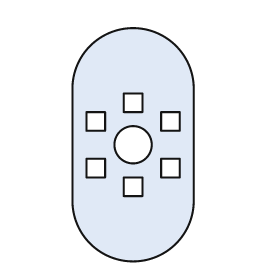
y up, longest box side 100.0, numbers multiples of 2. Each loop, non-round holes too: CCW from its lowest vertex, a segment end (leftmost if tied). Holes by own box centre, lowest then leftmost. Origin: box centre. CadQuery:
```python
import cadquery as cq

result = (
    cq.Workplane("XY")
    .moveTo(-26.0, -24.0)
    .threePointArc((0.0, -50.0), (26.0, -24.0))
    .lineTo(26.0, 24.0)
    .threePointArc((0.0, 50.0), (-26.0, 24.0))
    .close()
    .moveTo(-4.0, -22.0)
    .lineTo(4.0, -22.0)
    .lineTo(4.0, -14.0)
    .lineTo(-4.0, -14.0)
    .close()
    .moveTo(-20.0, -14.0)
    .lineTo(-12.0, -14.0)
    .lineTo(-12.0, -6.0)
    .lineTo(-20.0, -6.0)
    .close()
    .moveTo(12.0, -14.0)
    .lineTo(20.0, -14.0)
    .lineTo(20.0, -6.0)
    .lineTo(12.0, -6.0)
    .close()
    .moveTo(0.0, 0.0)
    .circle(8.0)
    .moveTo(-20.0, 6.0)
    .lineTo(-12.0, 6.0)
    .lineTo(-12.0, 14.0)
    .lineTo(-20.0, 14.0)
    .close()
    .moveTo(12.0, 6.0)
    .lineTo(20.0, 6.0)
    .lineTo(20.0, 14.0)
    .lineTo(12.0, 14.0)
    .close()
    .moveTo(-4.0, 14.0)
    .lineTo(4.0, 14.0)
    .lineTo(4.0, 22.0)
    .lineTo(-4.0, 22.0)
    .close()
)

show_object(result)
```